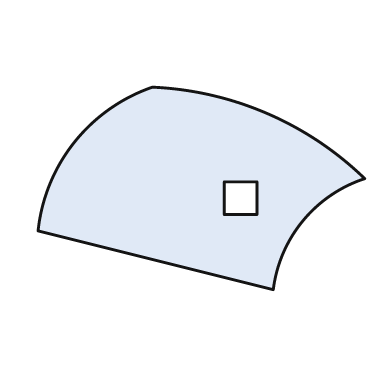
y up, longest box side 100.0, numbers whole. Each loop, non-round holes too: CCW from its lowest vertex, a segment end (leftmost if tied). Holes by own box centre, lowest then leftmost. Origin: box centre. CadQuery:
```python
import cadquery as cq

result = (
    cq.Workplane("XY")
    .moveTo(22.0, -31.0)
    .threePointArc((31.0, -10.0), (50.0, 3.0))
    .threePointArc((20.0, 23.0), (-15.0, 31.0))
    .threePointArc((-39.0, 14.0), (-50.0, -13.0))
    .close()
    .moveTo(7.0, -8.0)
    .lineTo(17.0, -8.0)
    .lineTo(17.0, 2.0)
    .lineTo(7.0, 2.0)
    .close()
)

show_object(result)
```